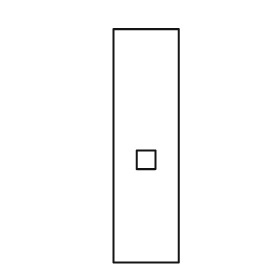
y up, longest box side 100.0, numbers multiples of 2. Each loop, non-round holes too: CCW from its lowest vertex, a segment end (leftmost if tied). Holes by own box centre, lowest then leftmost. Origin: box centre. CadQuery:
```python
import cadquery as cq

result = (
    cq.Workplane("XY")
    .moveTo(-14.0, -50.0)
    .lineTo(14.0, -50.0)
    .lineTo(14.0, 50.0)
    .lineTo(-14.0, 50.0)
    .close()
    .moveTo(-4.0, -10.0)
    .lineTo(4.0, -10.0)
    .lineTo(4.0, -2.0)
    .lineTo(-4.0, -2.0)
    .close()
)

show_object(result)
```